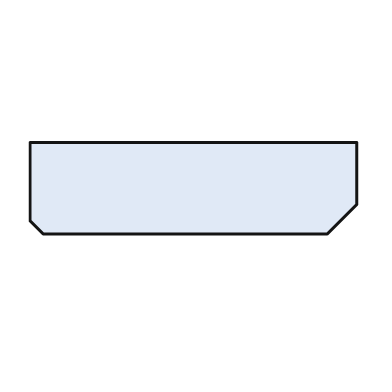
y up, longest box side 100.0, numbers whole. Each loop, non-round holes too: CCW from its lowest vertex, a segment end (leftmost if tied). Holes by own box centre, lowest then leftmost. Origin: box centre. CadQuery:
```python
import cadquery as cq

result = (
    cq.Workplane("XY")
    .moveTo(-46.0, -14.0)
    .lineTo(41.0, -14.0)
    .lineTo(50.0, -5.0)
    .lineTo(50.0, 14.0)
    .lineTo(-50.0, 14.0)
    .lineTo(-50.0, -10.0)
    .close()
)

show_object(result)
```